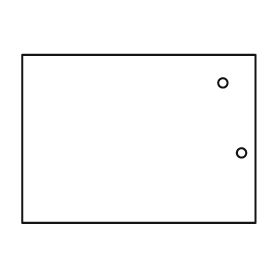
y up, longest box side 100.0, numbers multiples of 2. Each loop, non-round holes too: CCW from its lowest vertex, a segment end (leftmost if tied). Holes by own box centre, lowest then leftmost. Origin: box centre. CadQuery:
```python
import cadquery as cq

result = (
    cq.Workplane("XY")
    .moveTo(-50.0, -36.0)
    .lineTo(50.0, -36.0)
    .lineTo(50.0, 36.0)
    .lineTo(-50.0, 36.0)
    .close()
    .moveTo(44.0, -6.0)
    .circle(2.0)
    .moveTo(36.0, 24.0)
    .circle(2.0)
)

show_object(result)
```